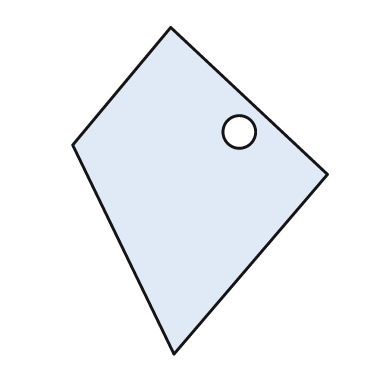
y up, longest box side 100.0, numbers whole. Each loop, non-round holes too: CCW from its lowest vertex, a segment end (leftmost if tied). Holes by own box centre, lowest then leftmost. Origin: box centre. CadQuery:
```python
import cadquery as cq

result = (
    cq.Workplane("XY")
    .moveTo(-8.0, -50.0)
    .lineTo(39.0, 5.0)
    .lineTo(-9.0, 50.0)
    .lineTo(-39.0, 14.0)
    .close()
    .moveTo(12.0, 18.0)
    .circle(5.0)
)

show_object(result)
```